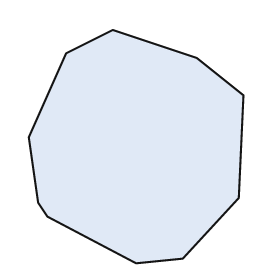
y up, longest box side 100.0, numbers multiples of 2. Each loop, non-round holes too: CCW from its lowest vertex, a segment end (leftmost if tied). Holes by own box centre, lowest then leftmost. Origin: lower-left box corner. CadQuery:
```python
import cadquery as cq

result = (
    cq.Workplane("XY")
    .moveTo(46.0, 0.0)
    .lineTo(66.0, 2.0)
    .lineTo(90.0, 28.0)
    .lineTo(92.0, 72.0)
    .lineTo(72.0, 88.0)
    .lineTo(36.0, 100.0)
    .lineTo(16.0, 90.0)
    .lineTo(0.0, 54.0)
    .lineTo(4.0, 26.0)
    .lineTo(8.0, 20.0)
    .close()
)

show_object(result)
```